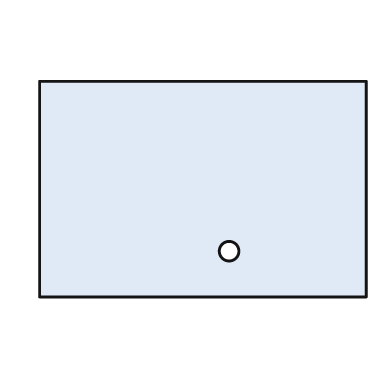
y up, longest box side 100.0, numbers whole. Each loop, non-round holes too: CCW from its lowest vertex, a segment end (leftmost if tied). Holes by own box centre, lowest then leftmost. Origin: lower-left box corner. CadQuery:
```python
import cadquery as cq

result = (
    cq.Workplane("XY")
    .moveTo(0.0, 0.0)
    .lineTo(100.0, 0.0)
    .lineTo(100.0, 66.0)
    .lineTo(0.0, 66.0)
    .close()
    .moveTo(58.0, 14.0)
    .circle(3.0)
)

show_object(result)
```